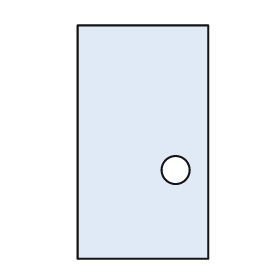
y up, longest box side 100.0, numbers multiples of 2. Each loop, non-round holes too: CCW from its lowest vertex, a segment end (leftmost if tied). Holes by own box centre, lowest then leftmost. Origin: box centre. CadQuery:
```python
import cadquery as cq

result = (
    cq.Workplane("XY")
    .moveTo(-28.0, -50.0)
    .lineTo(28.0, -50.0)
    .lineTo(28.0, 50.0)
    .lineTo(-28.0, 50.0)
    .close()
    .moveTo(14.0, -12.0)
    .circle(6.0)
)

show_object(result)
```